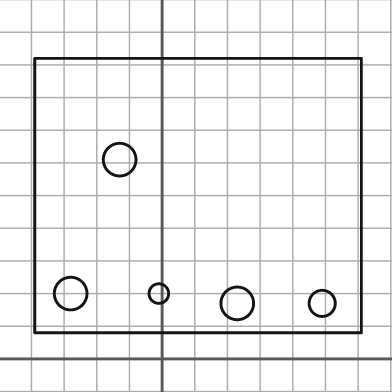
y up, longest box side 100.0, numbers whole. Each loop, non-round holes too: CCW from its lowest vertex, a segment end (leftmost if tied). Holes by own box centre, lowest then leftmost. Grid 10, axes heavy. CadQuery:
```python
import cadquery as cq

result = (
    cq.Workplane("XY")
    .moveTo(-39.0, 8.0)
    .lineTo(61.0, 8.0)
    .lineTo(61.0, 92.0)
    .lineTo(-39.0, 92.0)
    .close()
    .moveTo(23.0, 17.0)
    .circle(5.0)
    .moveTo(49.0, 17.0)
    .circle(4.0)
    .moveTo(-28.0, 20.0)
    .circle(5.0)
    .moveTo(-1.0, 20.0)
    .circle(3.0)
    .moveTo(-13.0, 61.0)
    .circle(5.0)
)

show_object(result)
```